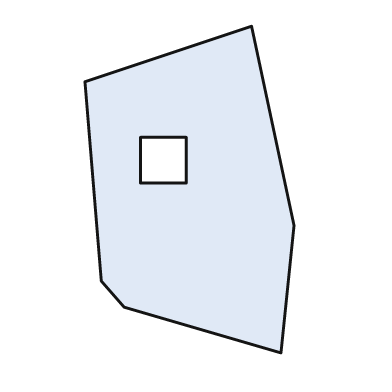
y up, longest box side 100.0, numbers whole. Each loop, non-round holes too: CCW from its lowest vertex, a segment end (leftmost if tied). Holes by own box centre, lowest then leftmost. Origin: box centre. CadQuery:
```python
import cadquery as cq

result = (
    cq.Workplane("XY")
    .moveTo(28.0, -50.0)
    .lineTo(32.0, -11.0)
    .lineTo(19.0, 50.0)
    .lineTo(-32.0, 33.0)
    .lineTo(-27.0, -28.0)
    .lineTo(-20.0, -36.0)
    .close()
    .moveTo(-15.0, 2.0)
    .lineTo(-1.0, 2.0)
    .lineTo(-1.0, 16.0)
    .lineTo(-15.0, 16.0)
    .close()
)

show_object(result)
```